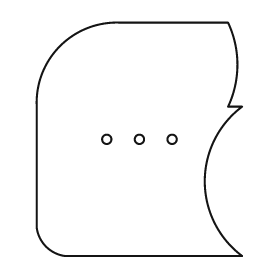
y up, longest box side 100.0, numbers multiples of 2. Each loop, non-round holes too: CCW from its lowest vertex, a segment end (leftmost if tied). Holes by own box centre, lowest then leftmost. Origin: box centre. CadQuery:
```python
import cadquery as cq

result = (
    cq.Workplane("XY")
    .moveTo(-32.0, -50.0)
    .lineTo(44.0, -50.0)
    .threePointArc((28.0, -18.0), (44.0, 14.0))
    .lineTo(38.0, 14.0)
    .threePointArc((42.0, 32.0), (38.0, 50.0))
    .lineTo(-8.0, 50.0)
    .threePointArc((-34.0, 40.0), (-44.0, 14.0))
    .lineTo(-44.0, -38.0)
    .threePointArc((-40.0, -46.0), (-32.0, -50.0))
    .close()
    .moveTo(-14.0, 0.0)
    .circle(2.0)
    .moveTo(0.0, 0.0)
    .circle(2.0)
    .moveTo(14.0, 0.0)
    .circle(2.0)
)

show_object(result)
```